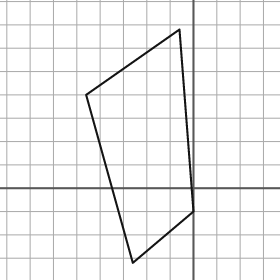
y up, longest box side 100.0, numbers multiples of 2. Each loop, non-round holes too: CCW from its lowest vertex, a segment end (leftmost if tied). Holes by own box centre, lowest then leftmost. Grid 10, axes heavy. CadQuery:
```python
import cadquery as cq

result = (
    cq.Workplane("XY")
    .moveTo(-26.0, -32.0)
    .lineTo(0.0, -10.0)
    .lineTo(-6.0, 68.0)
    .lineTo(-46.0, 40.0)
    .close()
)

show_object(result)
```